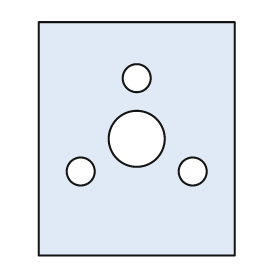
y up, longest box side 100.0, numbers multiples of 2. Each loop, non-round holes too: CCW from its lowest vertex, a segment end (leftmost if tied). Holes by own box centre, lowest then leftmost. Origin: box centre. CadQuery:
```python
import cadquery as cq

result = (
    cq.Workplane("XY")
    .moveTo(-42.0, -50.0)
    .lineTo(42.0, -50.0)
    .lineTo(42.0, 50.0)
    .lineTo(-42.0, 50.0)
    .close()
    .moveTo(-24.0, -14.0)
    .circle(6.0)
    .moveTo(24.0, -14.0)
    .circle(6.0)
    .moveTo(0.0, 0.0)
    .circle(12.0)
    .moveTo(0.0, 26.0)
    .circle(6.0)
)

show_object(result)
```